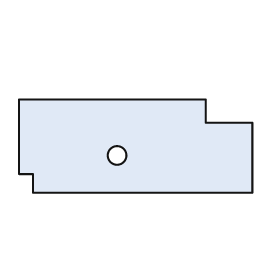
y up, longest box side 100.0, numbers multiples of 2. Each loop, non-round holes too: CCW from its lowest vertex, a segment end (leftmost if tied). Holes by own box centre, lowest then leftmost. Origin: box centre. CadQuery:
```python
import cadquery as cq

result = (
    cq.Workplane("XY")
    .moveTo(-44.0, -20.0)
    .lineTo(50.0, -20.0)
    .lineTo(50.0, 10.0)
    .lineTo(30.0, 10.0)
    .lineTo(30.0, 20.0)
    .lineTo(-50.0, 20.0)
    .lineTo(-50.0, -12.0)
    .lineTo(-44.0, -12.0)
    .close()
    .moveTo(-8.0, -4.0)
    .circle(4.0)
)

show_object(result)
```